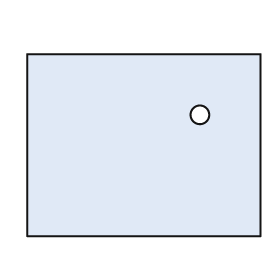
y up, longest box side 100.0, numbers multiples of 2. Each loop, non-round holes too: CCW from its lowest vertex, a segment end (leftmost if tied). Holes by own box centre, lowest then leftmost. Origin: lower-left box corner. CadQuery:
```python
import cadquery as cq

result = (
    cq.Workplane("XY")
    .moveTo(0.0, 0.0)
    .lineTo(100.0, 0.0)
    .lineTo(100.0, 78.0)
    .lineTo(0.0, 78.0)
    .close()
    .moveTo(74.0, 52.0)
    .circle(4.0)
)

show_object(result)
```